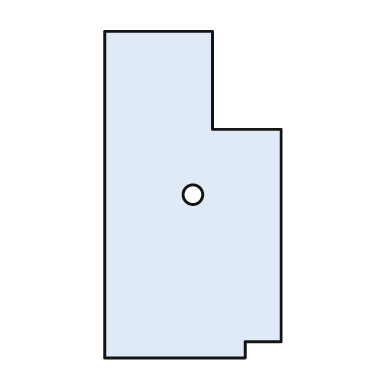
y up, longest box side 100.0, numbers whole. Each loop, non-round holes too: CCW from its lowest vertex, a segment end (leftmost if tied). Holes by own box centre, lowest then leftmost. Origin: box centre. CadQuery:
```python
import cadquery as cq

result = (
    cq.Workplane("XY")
    .moveTo(-27.0, -50.0)
    .lineTo(16.0, -50.0)
    .lineTo(16.0, -45.0)
    .lineTo(27.0, -45.0)
    .lineTo(27.0, 20.0)
    .lineTo(6.0, 20.0)
    .lineTo(6.0, 50.0)
    .lineTo(-27.0, 50.0)
    .close()
    .moveTo(0.0, 0.0)
    .circle(3.0)
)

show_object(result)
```